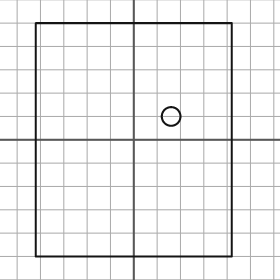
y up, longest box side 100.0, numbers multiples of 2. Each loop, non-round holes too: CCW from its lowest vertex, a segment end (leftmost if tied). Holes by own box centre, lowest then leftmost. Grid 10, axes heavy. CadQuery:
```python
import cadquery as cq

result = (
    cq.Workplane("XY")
    .moveTo(-42.0, -50.0)
    .lineTo(42.0, -50.0)
    .lineTo(42.0, 50.0)
    .lineTo(-42.0, 50.0)
    .close()
    .moveTo(16.0, 10.0)
    .circle(4.0)
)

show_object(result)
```